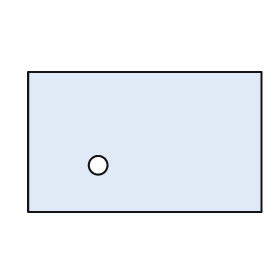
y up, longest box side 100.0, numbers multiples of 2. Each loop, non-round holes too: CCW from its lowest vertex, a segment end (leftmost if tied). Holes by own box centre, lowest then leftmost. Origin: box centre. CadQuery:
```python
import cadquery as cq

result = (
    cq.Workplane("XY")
    .moveTo(-50.0, -30.0)
    .lineTo(50.0, -30.0)
    .lineTo(50.0, 30.0)
    .lineTo(-50.0, 30.0)
    .close()
    .moveTo(-20.0, -10.0)
    .circle(4.0)
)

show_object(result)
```